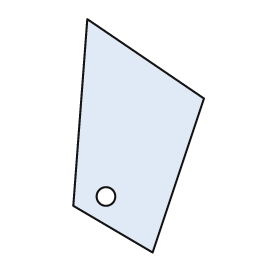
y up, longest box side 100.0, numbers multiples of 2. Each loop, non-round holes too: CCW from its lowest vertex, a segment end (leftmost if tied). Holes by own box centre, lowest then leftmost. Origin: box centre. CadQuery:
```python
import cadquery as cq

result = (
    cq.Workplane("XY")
    .moveTo(6.0, -50.0)
    .lineTo(28.0, 16.0)
    .lineTo(-22.0, 50.0)
    .lineTo(-28.0, -30.0)
    .close()
    .moveTo(-14.0, -26.0)
    .circle(4.0)
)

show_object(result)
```